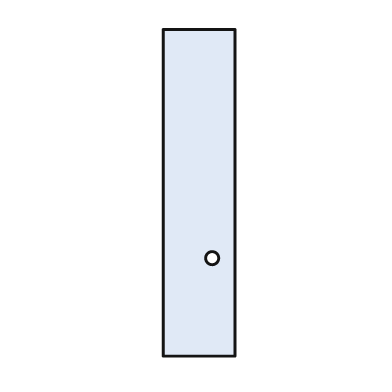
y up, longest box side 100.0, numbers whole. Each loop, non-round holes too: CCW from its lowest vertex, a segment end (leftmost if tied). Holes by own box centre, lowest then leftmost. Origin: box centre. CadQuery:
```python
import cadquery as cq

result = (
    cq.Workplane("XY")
    .moveTo(-11.0, -50.0)
    .lineTo(11.0, -50.0)
    .lineTo(11.0, 50.0)
    .lineTo(-11.0, 50.0)
    .close()
    .moveTo(4.0, -20.0)
    .circle(2.0)
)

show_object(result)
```